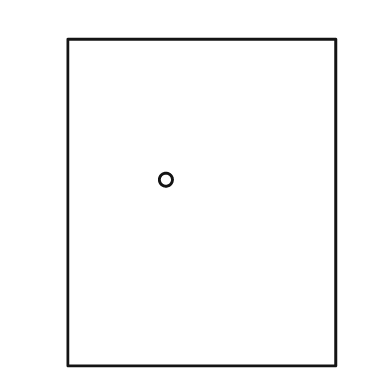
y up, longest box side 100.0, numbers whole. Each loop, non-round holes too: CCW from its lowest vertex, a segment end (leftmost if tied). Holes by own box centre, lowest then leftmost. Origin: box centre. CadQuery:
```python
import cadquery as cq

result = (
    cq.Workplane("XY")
    .moveTo(-41.0, -50.0)
    .lineTo(41.0, -50.0)
    .lineTo(41.0, 50.0)
    .lineTo(-41.0, 50.0)
    .close()
    .moveTo(-11.0, 7.0)
    .circle(2.0)
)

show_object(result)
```